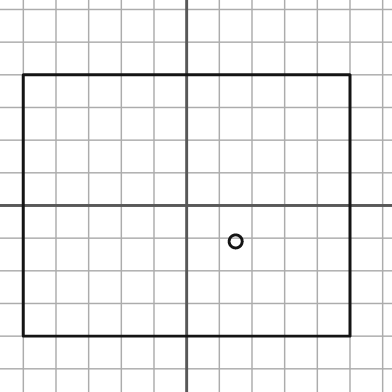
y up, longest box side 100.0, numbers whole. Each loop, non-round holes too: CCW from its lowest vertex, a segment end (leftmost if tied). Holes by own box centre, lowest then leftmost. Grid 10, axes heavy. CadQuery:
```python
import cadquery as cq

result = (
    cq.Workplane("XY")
    .moveTo(-50.0, -40.0)
    .lineTo(50.0, -40.0)
    .lineTo(50.0, 40.0)
    .lineTo(-50.0, 40.0)
    .close()
    .moveTo(15.0, -11.0)
    .circle(2.0)
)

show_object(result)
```